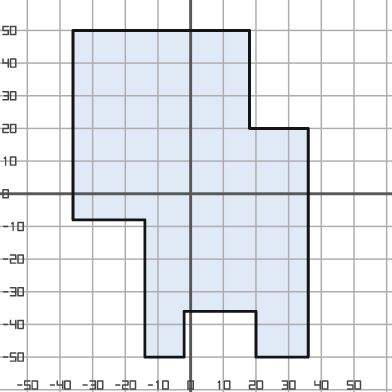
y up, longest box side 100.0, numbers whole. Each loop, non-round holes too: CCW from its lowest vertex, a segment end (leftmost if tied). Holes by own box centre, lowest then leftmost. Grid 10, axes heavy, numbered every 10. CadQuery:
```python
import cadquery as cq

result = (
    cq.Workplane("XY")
    .moveTo(-14.0, -50.0)
    .lineTo(-2.0, -50.0)
    .lineTo(-2.0, -36.0)
    .lineTo(20.0, -36.0)
    .lineTo(20.0, -50.0)
    .lineTo(36.0, -50.0)
    .lineTo(36.0, 20.0)
    .lineTo(18.0, 20.0)
    .lineTo(18.0, 50.0)
    .lineTo(-36.0, 50.0)
    .lineTo(-36.0, -8.0)
    .lineTo(-14.0, -8.0)
    .close()
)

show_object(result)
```